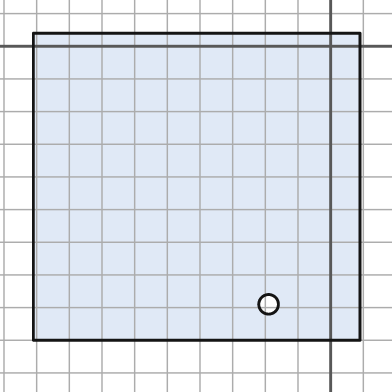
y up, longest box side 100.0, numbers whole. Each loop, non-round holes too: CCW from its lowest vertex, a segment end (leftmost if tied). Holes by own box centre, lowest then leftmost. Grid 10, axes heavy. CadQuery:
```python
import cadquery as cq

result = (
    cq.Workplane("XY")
    .moveTo(-91.0, -90.0)
    .lineTo(9.0, -90.0)
    .lineTo(9.0, 4.0)
    .lineTo(-91.0, 4.0)
    .close()
    .moveTo(-19.0, -79.0)
    .circle(3.0)
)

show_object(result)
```